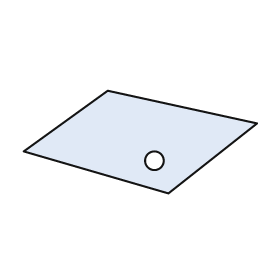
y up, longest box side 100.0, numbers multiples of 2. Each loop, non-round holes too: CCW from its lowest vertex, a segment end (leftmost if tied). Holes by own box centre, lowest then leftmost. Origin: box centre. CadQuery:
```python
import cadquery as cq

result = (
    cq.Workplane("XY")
    .moveTo(12.0, -22.0)
    .lineTo(50.0, 8.0)
    .lineTo(-14.0, 22.0)
    .lineTo(-50.0, -4.0)
    .close()
    .moveTo(6.0, -8.0)
    .circle(4.0)
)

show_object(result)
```